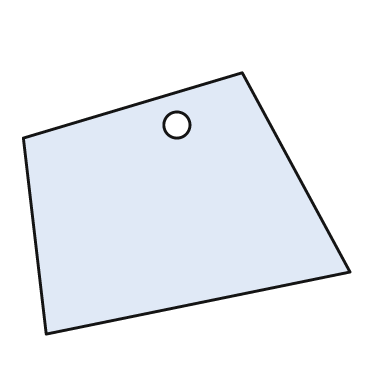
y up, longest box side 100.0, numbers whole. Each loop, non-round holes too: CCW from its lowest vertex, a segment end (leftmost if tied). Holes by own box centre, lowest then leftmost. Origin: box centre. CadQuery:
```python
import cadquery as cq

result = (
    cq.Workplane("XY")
    .moveTo(-43.0, -40.0)
    .lineTo(50.0, -21.0)
    .lineTo(17.0, 40.0)
    .lineTo(-50.0, 20.0)
    .close()
    .moveTo(-3.0, 24.0)
    .circle(4.0)
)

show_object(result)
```